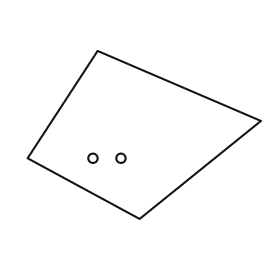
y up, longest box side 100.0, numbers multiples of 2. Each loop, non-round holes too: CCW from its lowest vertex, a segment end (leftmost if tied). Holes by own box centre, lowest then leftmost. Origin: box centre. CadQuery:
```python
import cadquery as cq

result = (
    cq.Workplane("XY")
    .moveTo(-2.0, -36.0)
    .lineTo(50.0, 6.0)
    .lineTo(-20.0, 36.0)
    .lineTo(-50.0, -10.0)
    .close()
    .moveTo(-22.0, -10.0)
    .circle(2.0)
    .moveTo(-10.0, -10.0)
    .circle(2.0)
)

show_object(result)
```